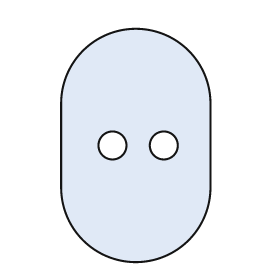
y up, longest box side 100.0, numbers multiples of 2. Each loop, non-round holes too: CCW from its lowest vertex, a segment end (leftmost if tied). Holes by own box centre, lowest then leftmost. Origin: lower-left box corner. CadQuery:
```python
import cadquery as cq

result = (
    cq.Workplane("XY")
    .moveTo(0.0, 32.0)
    .threePointArc((32.0, 0.0), (64.0, 32.0))
    .lineTo(64.0, 68.0)
    .threePointArc((32.0, 100.0), (0.0, 68.0))
    .close()
    .moveTo(22.0, 50.0)
    .circle(6.0)
    .moveTo(44.0, 50.0)
    .circle(6.0)
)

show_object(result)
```